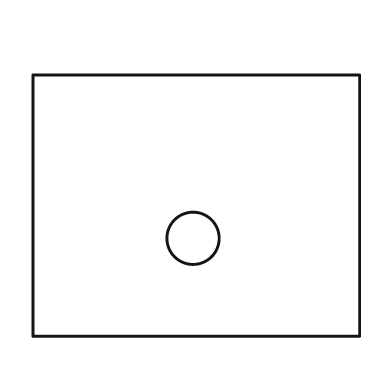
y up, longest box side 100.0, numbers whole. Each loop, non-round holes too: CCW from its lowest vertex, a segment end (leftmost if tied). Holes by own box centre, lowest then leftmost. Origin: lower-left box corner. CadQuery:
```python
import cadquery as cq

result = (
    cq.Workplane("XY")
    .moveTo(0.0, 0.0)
    .lineTo(100.0, 0.0)
    .lineTo(100.0, 80.0)
    .lineTo(0.0, 80.0)
    .close()
    .moveTo(49.0, 30.0)
    .circle(8.0)
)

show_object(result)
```